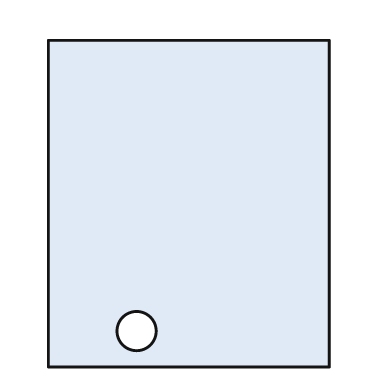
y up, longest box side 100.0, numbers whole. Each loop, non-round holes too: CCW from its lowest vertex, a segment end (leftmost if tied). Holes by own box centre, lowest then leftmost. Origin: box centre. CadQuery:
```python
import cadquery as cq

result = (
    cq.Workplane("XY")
    .moveTo(-43.0, -50.0)
    .lineTo(43.0, -50.0)
    .lineTo(43.0, 50.0)
    .lineTo(-43.0, 50.0)
    .close()
    .moveTo(-16.0, -39.0)
    .circle(6.0)
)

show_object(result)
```